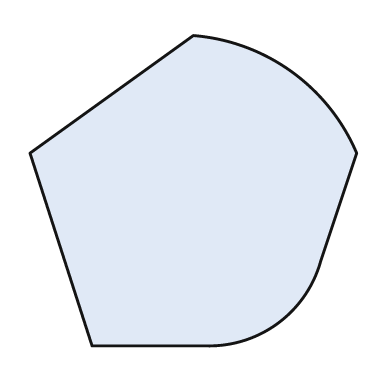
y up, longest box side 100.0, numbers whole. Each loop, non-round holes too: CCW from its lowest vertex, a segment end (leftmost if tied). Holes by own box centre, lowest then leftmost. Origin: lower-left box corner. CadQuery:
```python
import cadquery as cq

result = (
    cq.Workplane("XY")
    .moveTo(19.0, 0.0)
    .lineTo(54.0, 0.0)
    .threePointArc((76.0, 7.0), (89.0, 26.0))
    .lineTo(100.0, 59.0)
    .threePointArc((80.0, 84.0), (50.0, 95.0))
    .lineTo(0.0, 59.0)
    .close()
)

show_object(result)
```